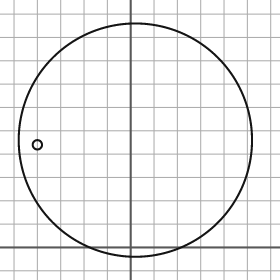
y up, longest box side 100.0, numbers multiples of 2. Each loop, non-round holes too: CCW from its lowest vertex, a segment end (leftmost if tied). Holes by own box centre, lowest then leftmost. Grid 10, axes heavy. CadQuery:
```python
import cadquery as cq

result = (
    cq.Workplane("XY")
    .moveTo(2.0, 46.0)
    .circle(50.0)
    .moveTo(-40.0, 44.0)
    .circle(2.0)
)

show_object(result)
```